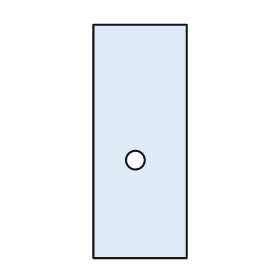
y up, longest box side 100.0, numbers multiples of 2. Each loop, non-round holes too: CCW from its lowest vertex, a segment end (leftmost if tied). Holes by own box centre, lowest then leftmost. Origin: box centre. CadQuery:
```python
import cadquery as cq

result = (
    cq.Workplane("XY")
    .moveTo(-20.0, -50.0)
    .lineTo(20.0, -50.0)
    .lineTo(20.0, 50.0)
    .lineTo(-20.0, 50.0)
    .close()
    .moveTo(-2.0, -8.0)
    .circle(4.0)
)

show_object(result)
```